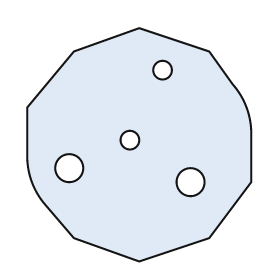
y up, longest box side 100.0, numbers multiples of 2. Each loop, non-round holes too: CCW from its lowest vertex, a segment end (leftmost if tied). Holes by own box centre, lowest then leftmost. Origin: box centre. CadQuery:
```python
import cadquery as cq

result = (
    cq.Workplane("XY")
    .moveTo(0.0, -50.0)
    .lineTo(30.0, -40.0)
    .lineTo(48.0, -16.0)
    .lineTo(48.0, 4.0)
    .threePointArc((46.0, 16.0), (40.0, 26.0))
    .lineTo(30.0, 40.0)
    .lineTo(0.0, 50.0)
    .lineTo(-28.0, 40.0)
    .lineTo(-48.0, 16.0)
    .lineTo(-48.0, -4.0)
    .threePointArc((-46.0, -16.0), (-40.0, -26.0))
    .lineTo(-28.0, -40.0)
    .close()
    .moveTo(22.0, -16.0)
    .circle(6.0)
    .moveTo(-30.0, -10.0)
    .circle(6.0)
    .moveTo(-4.0, 2.0)
    .circle(4.0)
    .moveTo(10.0, 32.0)
    .circle(4.0)
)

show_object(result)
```